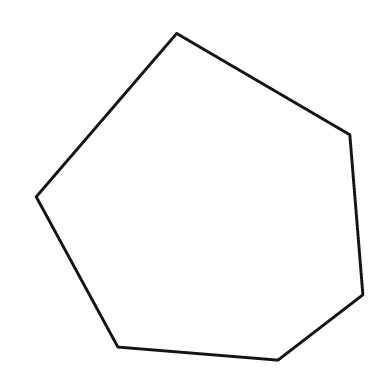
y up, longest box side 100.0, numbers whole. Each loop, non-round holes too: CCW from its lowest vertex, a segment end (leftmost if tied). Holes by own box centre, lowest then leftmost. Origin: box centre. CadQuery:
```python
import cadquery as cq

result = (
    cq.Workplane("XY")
    .moveTo(24.0, -50.0)
    .lineTo(50.0, -30.0)
    .lineTo(46.0, 19.0)
    .lineTo(-7.0, 50.0)
    .lineTo(-50.0, 0.0)
    .lineTo(-25.0, -46.0)
    .close()
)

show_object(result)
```